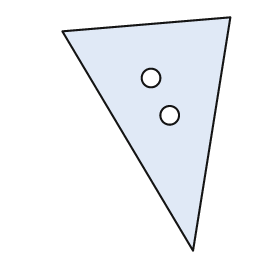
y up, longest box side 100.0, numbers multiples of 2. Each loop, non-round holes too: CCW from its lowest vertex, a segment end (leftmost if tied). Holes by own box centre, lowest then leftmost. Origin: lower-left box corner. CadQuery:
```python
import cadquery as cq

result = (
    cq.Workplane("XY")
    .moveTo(56.0, 0.0)
    .lineTo(72.0, 100.0)
    .lineTo(0.0, 94.0)
    .close()
    .moveTo(46.0, 58.0)
    .circle(4.0)
    .moveTo(38.0, 74.0)
    .circle(4.0)
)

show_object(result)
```